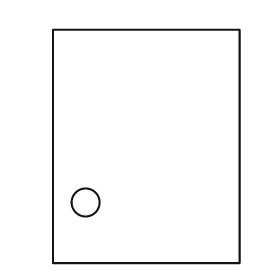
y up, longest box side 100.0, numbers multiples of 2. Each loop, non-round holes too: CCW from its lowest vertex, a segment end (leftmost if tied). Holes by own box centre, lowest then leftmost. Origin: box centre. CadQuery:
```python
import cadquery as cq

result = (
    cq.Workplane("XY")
    .moveTo(-40.0, -50.0)
    .lineTo(40.0, -50.0)
    .lineTo(40.0, 50.0)
    .lineTo(-40.0, 50.0)
    .close()
    .moveTo(-26.0, -24.0)
    .circle(6.0)
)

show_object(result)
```